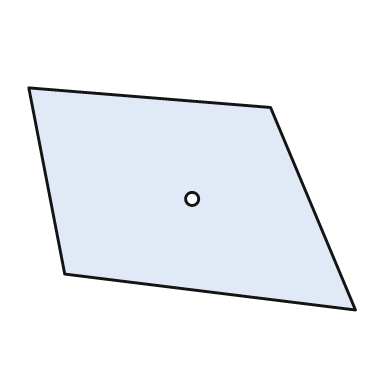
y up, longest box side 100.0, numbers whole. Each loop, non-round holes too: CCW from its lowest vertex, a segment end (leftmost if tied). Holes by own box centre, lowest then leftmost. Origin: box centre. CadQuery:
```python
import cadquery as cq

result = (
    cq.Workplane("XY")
    .moveTo(50.0, -34.0)
    .lineTo(24.0, 28.0)
    .lineTo(-50.0, 34.0)
    .lineTo(-39.0, -23.0)
    .close()
    .moveTo(0.0, 0.0)
    .circle(2.0)
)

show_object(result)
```